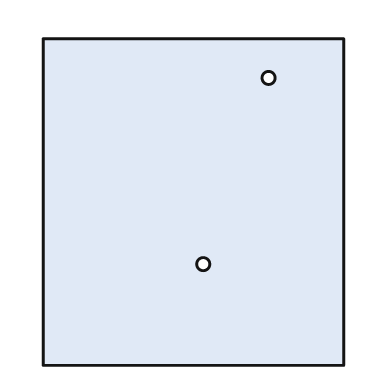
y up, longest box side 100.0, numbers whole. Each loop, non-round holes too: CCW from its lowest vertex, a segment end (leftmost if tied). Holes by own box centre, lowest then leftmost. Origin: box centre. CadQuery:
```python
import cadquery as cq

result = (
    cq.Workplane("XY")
    .moveTo(-46.0, -50.0)
    .lineTo(46.0, -50.0)
    .lineTo(46.0, 50.0)
    .lineTo(-46.0, 50.0)
    .close()
    .moveTo(3.0, -19.0)
    .circle(2.0)
    .moveTo(23.0, 38.0)
    .circle(2.0)
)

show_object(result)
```